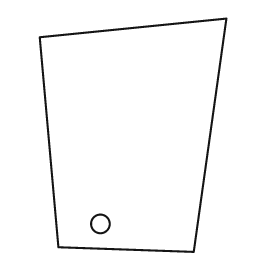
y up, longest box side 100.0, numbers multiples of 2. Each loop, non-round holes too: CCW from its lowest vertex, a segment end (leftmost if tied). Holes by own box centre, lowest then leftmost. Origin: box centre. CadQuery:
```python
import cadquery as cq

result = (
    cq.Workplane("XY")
    .moveTo(26.0, -50.0)
    .lineTo(40.0, 50.0)
    .lineTo(-40.0, 42.0)
    .lineTo(-32.0, -48.0)
    .close()
    .moveTo(-14.0, -38.0)
    .circle(4.0)
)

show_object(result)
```